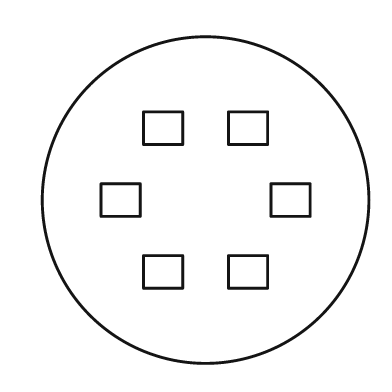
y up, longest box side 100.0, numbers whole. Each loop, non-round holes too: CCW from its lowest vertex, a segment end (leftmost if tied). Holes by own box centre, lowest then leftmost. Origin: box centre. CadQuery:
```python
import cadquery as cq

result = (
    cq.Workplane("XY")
    .moveTo(0.0, 0.0)
    .circle(50.0)
    .moveTo(-19.0, -27.0)
    .lineTo(-7.0, -27.0)
    .lineTo(-7.0, -17.0)
    .lineTo(-19.0, -17.0)
    .close()
    .moveTo(7.0, -27.0)
    .lineTo(19.0, -27.0)
    .lineTo(19.0, -17.0)
    .lineTo(7.0, -17.0)
    .close()
    .moveTo(-32.0, -5.0)
    .lineTo(-20.0, -5.0)
    .lineTo(-20.0, 5.0)
    .lineTo(-32.0, 5.0)
    .close()
    .moveTo(20.0, -5.0)
    .lineTo(32.0, -5.0)
    .lineTo(32.0, 5.0)
    .lineTo(20.0, 5.0)
    .close()
    .moveTo(-19.0, 17.0)
    .lineTo(-7.0, 17.0)
    .lineTo(-7.0, 27.0)
    .lineTo(-19.0, 27.0)
    .close()
    .moveTo(7.0, 17.0)
    .lineTo(19.0, 17.0)
    .lineTo(19.0, 27.0)
    .lineTo(7.0, 27.0)
    .close()
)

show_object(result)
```